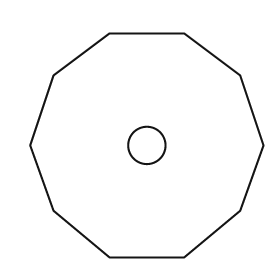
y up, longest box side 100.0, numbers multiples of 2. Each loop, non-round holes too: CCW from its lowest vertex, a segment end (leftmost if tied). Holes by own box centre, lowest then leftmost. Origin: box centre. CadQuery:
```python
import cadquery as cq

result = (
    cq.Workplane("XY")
    .moveTo(-16.0, -48.0)
    .lineTo(16.0, -48.0)
    .lineTo(40.0, -28.0)
    .lineTo(50.0, 0.0)
    .lineTo(40.0, 30.0)
    .lineTo(16.0, 48.0)
    .lineTo(-16.0, 48.0)
    .lineTo(-40.0, 30.0)
    .lineTo(-50.0, 0.0)
    .lineTo(-40.0, -28.0)
    .close()
    .moveTo(0.0, 0.0)
    .circle(8.0)
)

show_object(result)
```